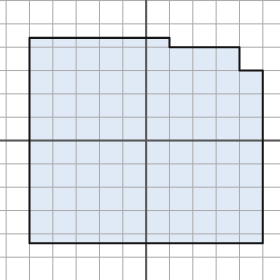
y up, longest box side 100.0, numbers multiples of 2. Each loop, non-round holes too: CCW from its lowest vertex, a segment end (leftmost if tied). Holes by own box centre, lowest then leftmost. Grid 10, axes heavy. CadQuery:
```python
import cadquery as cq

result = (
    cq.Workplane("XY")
    .moveTo(-50.0, -44.0)
    .lineTo(50.0, -44.0)
    .lineTo(50.0, 30.0)
    .lineTo(40.0, 30.0)
    .lineTo(40.0, 40.0)
    .lineTo(10.0, 40.0)
    .lineTo(10.0, 44.0)
    .lineTo(-50.0, 44.0)
    .close()
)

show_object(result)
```